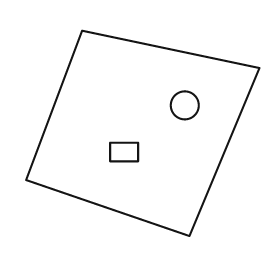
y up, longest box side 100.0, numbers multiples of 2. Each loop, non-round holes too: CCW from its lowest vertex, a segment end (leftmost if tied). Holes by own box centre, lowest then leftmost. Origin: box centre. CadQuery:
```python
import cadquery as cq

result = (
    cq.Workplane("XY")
    .moveTo(20.0, -44.0)
    .lineTo(50.0, 28.0)
    .lineTo(-26.0, 44.0)
    .lineTo(-50.0, -20.0)
    .close()
    .moveTo(-14.0, -12.0)
    .lineTo(-2.0, -12.0)
    .lineTo(-2.0, -4.0)
    .lineTo(-14.0, -4.0)
    .close()
    .moveTo(18.0, 12.0)
    .circle(6.0)
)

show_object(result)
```